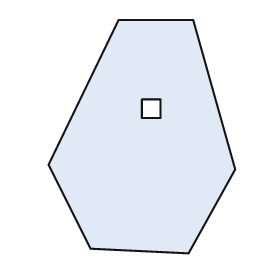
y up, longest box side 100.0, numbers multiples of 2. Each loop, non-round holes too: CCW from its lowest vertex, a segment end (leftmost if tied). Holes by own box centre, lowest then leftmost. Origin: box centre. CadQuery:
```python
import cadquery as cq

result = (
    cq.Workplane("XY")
    .moveTo(20.0, -50.0)
    .lineTo(40.0, -14.0)
    .lineTo(22.0, 50.0)
    .lineTo(-10.0, 50.0)
    .lineTo(-40.0, -12.0)
    .lineTo(-22.0, -48.0)
    .close()
    .moveTo(0.0, 8.0)
    .lineTo(8.0, 8.0)
    .lineTo(8.0, 16.0)
    .lineTo(0.0, 16.0)
    .close()
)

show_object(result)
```